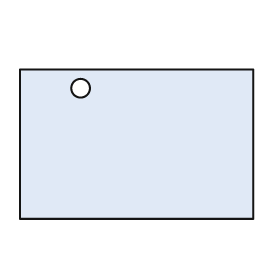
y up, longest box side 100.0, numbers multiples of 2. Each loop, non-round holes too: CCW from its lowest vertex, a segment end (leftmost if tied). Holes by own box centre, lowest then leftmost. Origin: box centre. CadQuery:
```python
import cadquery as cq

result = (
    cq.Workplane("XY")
    .moveTo(-50.0, -32.0)
    .lineTo(50.0, -32.0)
    .lineTo(50.0, 32.0)
    .lineTo(-50.0, 32.0)
    .close()
    .moveTo(-24.0, 24.0)
    .circle(4.0)
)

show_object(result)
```